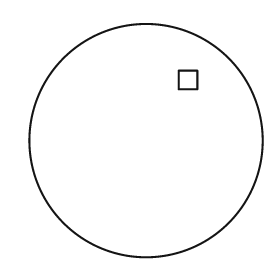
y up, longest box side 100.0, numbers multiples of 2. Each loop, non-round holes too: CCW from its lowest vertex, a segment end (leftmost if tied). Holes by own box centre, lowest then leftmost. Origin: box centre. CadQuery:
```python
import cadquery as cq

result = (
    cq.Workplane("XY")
    .moveTo(0.0, 0.0)
    .circle(50.0)
    .moveTo(14.0, 22.0)
    .lineTo(22.0, 22.0)
    .lineTo(22.0, 30.0)
    .lineTo(14.0, 30.0)
    .close()
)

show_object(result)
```